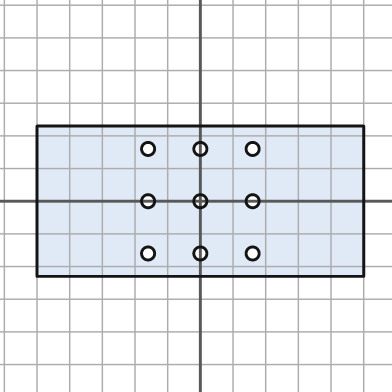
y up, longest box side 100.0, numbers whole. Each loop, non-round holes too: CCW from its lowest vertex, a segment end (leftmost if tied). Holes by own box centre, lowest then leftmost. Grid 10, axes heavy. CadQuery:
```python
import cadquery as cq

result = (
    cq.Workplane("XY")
    .moveTo(-50.0, -23.0)
    .lineTo(50.0, -23.0)
    .lineTo(50.0, 23.0)
    .lineTo(-50.0, 23.0)
    .close()
    .moveTo(-16.0, -16.0)
    .circle(2.0)
    .moveTo(0.0, -16.0)
    .circle(2.0)
    .moveTo(16.0, -16.0)
    .circle(2.0)
    .moveTo(-16.0, 0.0)
    .circle(2.0)
    .moveTo(0.0, 0.0)
    .circle(2.0)
    .moveTo(16.0, 0.0)
    .circle(2.0)
    .moveTo(-16.0, 16.0)
    .circle(2.0)
    .moveTo(0.0, 16.0)
    .circle(2.0)
    .moveTo(16.0, 16.0)
    .circle(2.0)
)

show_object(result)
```